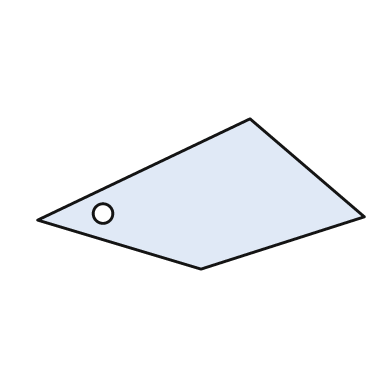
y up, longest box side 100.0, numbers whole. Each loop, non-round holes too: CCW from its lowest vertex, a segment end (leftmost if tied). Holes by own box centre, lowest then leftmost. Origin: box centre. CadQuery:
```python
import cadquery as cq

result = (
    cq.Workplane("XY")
    .moveTo(0.0, -23.0)
    .lineTo(50.0, -7.0)
    .lineTo(15.0, 23.0)
    .lineTo(-50.0, -8.0)
    .close()
    .moveTo(-30.0, -6.0)
    .circle(3.0)
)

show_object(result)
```